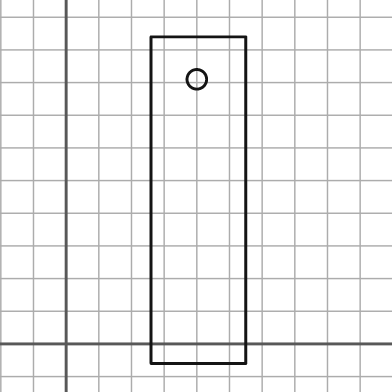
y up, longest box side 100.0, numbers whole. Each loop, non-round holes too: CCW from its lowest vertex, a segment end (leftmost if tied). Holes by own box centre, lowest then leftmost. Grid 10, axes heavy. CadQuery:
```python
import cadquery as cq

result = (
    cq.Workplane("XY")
    .moveTo(26.0, -6.0)
    .lineTo(55.0, -6.0)
    .lineTo(55.0, 94.0)
    .lineTo(26.0, 94.0)
    .close()
    .moveTo(40.0, 81.0)
    .circle(3.0)
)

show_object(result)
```